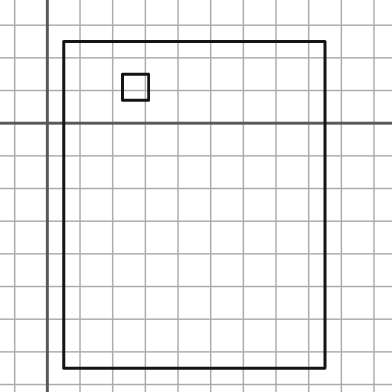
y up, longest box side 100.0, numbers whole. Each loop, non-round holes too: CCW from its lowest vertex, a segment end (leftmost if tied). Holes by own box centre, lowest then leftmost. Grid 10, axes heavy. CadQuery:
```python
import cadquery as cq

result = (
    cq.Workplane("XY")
    .moveTo(5.0, -75.0)
    .lineTo(85.0, -75.0)
    .lineTo(85.0, 25.0)
    .lineTo(5.0, 25.0)
    .close()
    .moveTo(23.0, 7.0)
    .lineTo(31.0, 7.0)
    .lineTo(31.0, 15.0)
    .lineTo(23.0, 15.0)
    .close()
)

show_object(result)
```